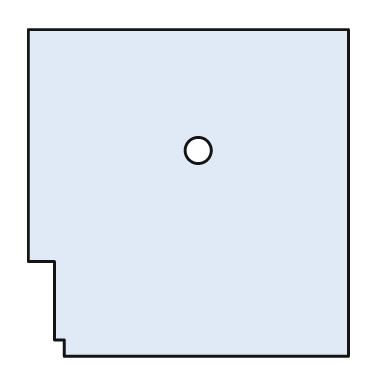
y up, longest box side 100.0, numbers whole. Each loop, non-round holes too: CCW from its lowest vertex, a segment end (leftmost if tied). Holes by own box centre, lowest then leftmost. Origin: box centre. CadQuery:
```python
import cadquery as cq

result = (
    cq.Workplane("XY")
    .moveTo(-38.0, -50.0)
    .lineTo(49.0, -50.0)
    .lineTo(49.0, 50.0)
    .lineTo(-49.0, 50.0)
    .lineTo(-49.0, -21.0)
    .lineTo(-41.0, -21.0)
    .lineTo(-41.0, -45.0)
    .lineTo(-38.0, -45.0)
    .close()
    .moveTo(3.0, 13.0)
    .circle(4.0)
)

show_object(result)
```